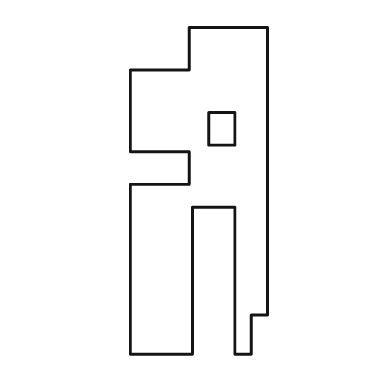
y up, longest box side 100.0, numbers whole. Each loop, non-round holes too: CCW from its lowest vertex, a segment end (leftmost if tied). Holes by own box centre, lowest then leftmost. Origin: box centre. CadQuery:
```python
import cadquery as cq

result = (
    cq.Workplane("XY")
    .moveTo(-21.0, -50.0)
    .lineTo(-2.0, -50.0)
    .lineTo(-2.0, -5.0)
    .lineTo(11.0, -5.0)
    .lineTo(11.0, -50.0)
    .lineTo(16.0, -50.0)
    .lineTo(16.0, -38.0)
    .lineTo(21.0, -38.0)
    .lineTo(21.0, 50.0)
    .lineTo(-3.0, 50.0)
    .lineTo(-3.0, 37.0)
    .lineTo(-21.0, 37.0)
    .lineTo(-21.0, 12.0)
    .lineTo(-3.0, 12.0)
    .lineTo(-3.0, 2.0)
    .lineTo(-21.0, 2.0)
    .close()
    .moveTo(3.0, 14.0)
    .lineTo(11.0, 14.0)
    .lineTo(11.0, 24.0)
    .lineTo(3.0, 24.0)
    .close()
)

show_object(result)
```